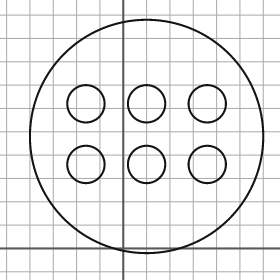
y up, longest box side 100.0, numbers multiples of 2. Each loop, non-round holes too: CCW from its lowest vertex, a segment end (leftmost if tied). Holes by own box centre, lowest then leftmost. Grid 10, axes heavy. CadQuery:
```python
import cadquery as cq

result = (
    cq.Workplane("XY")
    .moveTo(10.0, 48.0)
    .circle(50.0)
    .moveTo(-16.0, 36.0)
    .circle(8.0)
    .moveTo(10.0, 36.0)
    .circle(8.0)
    .moveTo(36.0, 36.0)
    .circle(8.0)
    .moveTo(-16.0, 62.0)
    .circle(8.0)
    .moveTo(10.0, 62.0)
    .circle(8.0)
    .moveTo(36.0, 62.0)
    .circle(8.0)
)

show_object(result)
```